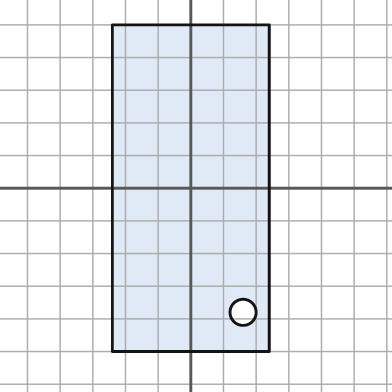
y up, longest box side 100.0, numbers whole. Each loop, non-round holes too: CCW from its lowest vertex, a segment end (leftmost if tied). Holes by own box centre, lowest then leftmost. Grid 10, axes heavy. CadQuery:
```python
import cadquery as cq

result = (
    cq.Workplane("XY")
    .moveTo(-24.0, -50.0)
    .lineTo(24.0, -50.0)
    .lineTo(24.0, 50.0)
    .lineTo(-24.0, 50.0)
    .close()
    .moveTo(16.0, -38.0)
    .circle(4.0)
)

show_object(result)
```